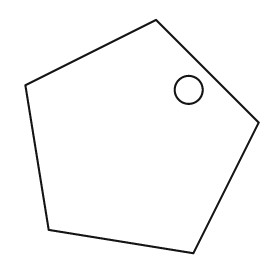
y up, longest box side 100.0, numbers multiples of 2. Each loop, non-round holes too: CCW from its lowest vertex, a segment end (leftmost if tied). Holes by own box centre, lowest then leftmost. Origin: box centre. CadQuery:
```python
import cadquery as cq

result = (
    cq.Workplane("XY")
    .moveTo(22.0, -50.0)
    .lineTo(50.0, 6.0)
    .lineTo(6.0, 50.0)
    .lineTo(-50.0, 22.0)
    .lineTo(-40.0, -40.0)
    .close()
    .moveTo(20.0, 20.0)
    .circle(6.0)
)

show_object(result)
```